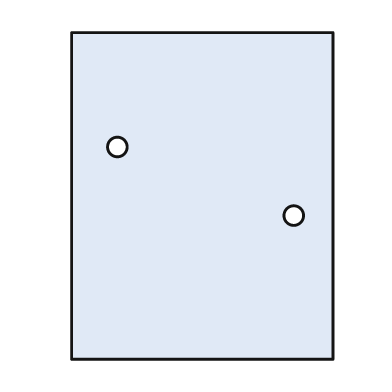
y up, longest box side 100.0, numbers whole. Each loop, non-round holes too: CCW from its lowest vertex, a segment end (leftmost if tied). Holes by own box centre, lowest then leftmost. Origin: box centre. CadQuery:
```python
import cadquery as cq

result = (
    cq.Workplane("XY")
    .moveTo(-40.0, -50.0)
    .lineTo(40.0, -50.0)
    .lineTo(40.0, 50.0)
    .lineTo(-40.0, 50.0)
    .close()
    .moveTo(28.0, -6.0)
    .circle(3.0)
    .moveTo(-26.0, 15.0)
    .circle(3.0)
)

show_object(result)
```